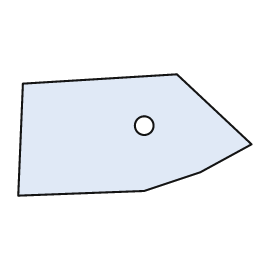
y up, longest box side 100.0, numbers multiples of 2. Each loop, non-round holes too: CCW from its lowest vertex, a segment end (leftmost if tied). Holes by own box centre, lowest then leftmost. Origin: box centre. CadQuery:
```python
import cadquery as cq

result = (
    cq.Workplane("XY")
    .moveTo(-50.0, -26.0)
    .lineTo(4.0, -24.0)
    .lineTo(28.0, -16.0)
    .lineTo(50.0, -4.0)
    .lineTo(18.0, 26.0)
    .lineTo(-48.0, 22.0)
    .close()
    .moveTo(4.0, 4.0)
    .circle(4.0)
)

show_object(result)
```